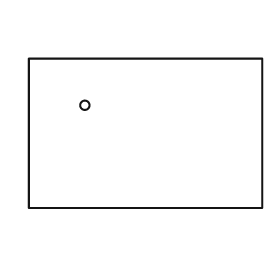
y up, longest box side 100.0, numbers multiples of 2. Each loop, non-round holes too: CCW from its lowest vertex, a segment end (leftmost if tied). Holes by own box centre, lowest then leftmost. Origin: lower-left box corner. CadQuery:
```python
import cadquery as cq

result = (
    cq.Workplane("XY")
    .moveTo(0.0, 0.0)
    .lineTo(100.0, 0.0)
    .lineTo(100.0, 64.0)
    .lineTo(0.0, 64.0)
    .close()
    .moveTo(24.0, 44.0)
    .circle(2.0)
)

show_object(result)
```